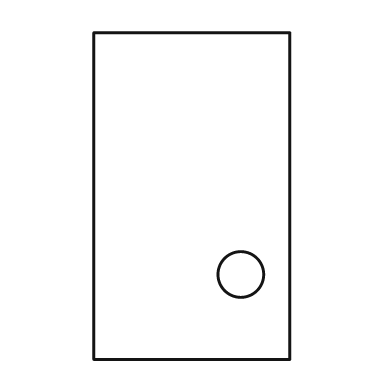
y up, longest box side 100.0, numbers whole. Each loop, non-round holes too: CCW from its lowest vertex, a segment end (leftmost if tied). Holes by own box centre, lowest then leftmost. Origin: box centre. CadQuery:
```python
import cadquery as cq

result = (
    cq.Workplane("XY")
    .moveTo(-30.0, -50.0)
    .lineTo(30.0, -50.0)
    .lineTo(30.0, 50.0)
    .lineTo(-30.0, 50.0)
    .close()
    .moveTo(15.0, -24.0)
    .circle(7.0)
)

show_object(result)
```